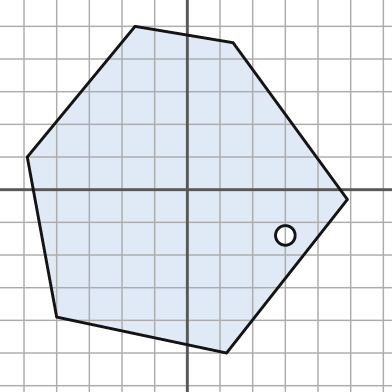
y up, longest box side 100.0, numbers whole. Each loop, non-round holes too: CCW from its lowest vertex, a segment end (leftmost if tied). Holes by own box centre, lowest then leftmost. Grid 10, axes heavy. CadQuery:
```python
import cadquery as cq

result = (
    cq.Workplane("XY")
    .moveTo(12.0, -50.0)
    .lineTo(49.0, -3.0)
    .lineTo(14.0, 45.0)
    .lineTo(-16.0, 50.0)
    .lineTo(-49.0, 10.0)
    .lineTo(-40.0, -39.0)
    .close()
    .moveTo(30.0, -14.0)
    .circle(3.0)
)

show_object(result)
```